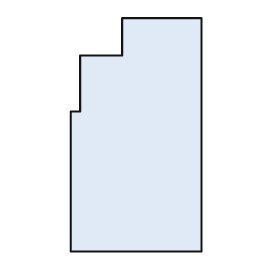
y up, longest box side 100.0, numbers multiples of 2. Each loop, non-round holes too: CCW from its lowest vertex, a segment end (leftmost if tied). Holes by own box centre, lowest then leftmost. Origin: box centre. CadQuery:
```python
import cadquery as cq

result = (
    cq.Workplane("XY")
    .moveTo(-28.0, -50.0)
    .lineTo(28.0, -50.0)
    .lineTo(28.0, 50.0)
    .lineTo(-6.0, 50.0)
    .lineTo(-6.0, 34.0)
    .lineTo(-24.0, 34.0)
    .lineTo(-24.0, 10.0)
    .lineTo(-28.0, 10.0)
    .close()
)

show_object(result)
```